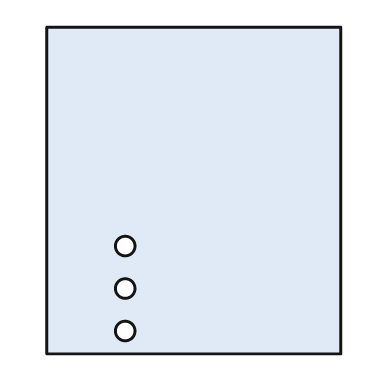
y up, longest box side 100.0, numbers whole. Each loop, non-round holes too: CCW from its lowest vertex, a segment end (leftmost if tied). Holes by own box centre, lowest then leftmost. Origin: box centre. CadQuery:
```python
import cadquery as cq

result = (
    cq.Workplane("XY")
    .moveTo(-45.0, -50.0)
    .lineTo(45.0, -50.0)
    .lineTo(45.0, 50.0)
    .lineTo(-45.0, 50.0)
    .close()
    .moveTo(-21.0, -43.0)
    .circle(3.0)
    .moveTo(-21.0, -30.0)
    .circle(3.0)
    .moveTo(-21.0, -17.0)
    .circle(3.0)
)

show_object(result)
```